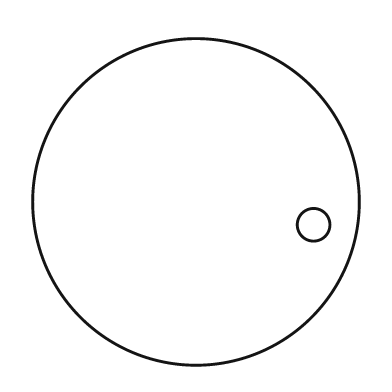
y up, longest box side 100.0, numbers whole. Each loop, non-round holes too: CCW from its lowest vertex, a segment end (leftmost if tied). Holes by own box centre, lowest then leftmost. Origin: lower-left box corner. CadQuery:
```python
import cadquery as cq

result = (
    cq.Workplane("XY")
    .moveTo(50.0, 50.0)
    .circle(50.0)
    .moveTo(86.0, 43.0)
    .circle(5.0)
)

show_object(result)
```